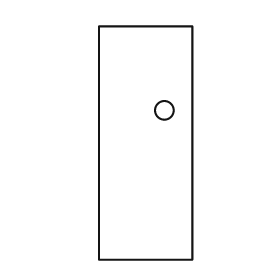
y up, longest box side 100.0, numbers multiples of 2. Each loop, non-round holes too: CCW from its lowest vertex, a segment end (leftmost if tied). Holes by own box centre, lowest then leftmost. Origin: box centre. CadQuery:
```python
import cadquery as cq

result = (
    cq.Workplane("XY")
    .moveTo(-20.0, -50.0)
    .lineTo(20.0, -50.0)
    .lineTo(20.0, 50.0)
    .lineTo(-20.0, 50.0)
    .close()
    .moveTo(8.0, 14.0)
    .circle(4.0)
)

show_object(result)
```